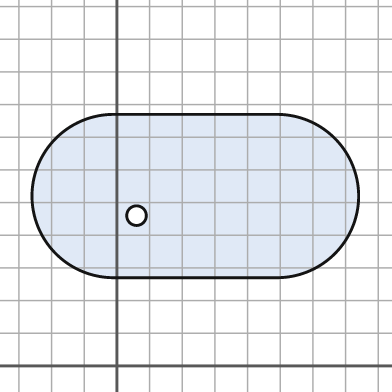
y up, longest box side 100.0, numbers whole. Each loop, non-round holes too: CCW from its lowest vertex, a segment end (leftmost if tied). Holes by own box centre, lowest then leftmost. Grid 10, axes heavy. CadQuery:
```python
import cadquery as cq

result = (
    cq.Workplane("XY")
    .moveTo(-1.0, 27.0)
    .lineTo(49.0, 27.0)
    .threePointArc((74.0, 52.0), (49.0, 77.0))
    .lineTo(-1.0, 77.0)
    .threePointArc((-26.0, 52.0), (-1.0, 27.0))
    .close()
    .moveTo(6.0, 46.0)
    .circle(3.0)
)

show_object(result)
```